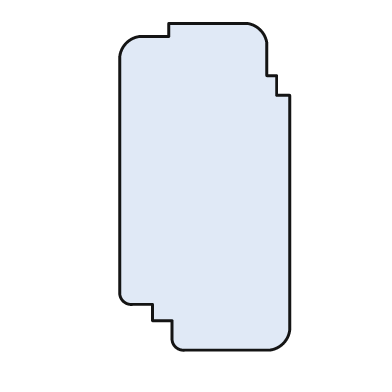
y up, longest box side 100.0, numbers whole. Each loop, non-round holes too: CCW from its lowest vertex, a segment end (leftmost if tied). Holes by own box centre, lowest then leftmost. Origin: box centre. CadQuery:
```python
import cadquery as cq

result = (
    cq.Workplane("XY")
    .moveTo(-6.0, -50.0)
    .lineTo(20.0, -50.0)
    .threePointArc((24.0, -48.0), (26.0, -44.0))
    .lineTo(26.0, 28.0)
    .lineTo(22.0, 28.0)
    .lineTo(22.0, 34.0)
    .lineTo(19.0, 34.0)
    .lineTo(19.0, 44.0)
    .threePointArc((17.0, 48.0), (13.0, 50.0))
    .lineTo(-11.0, 50.0)
    .lineTo(-11.0, 46.0)
    .lineTo(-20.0, 46.0)
    .threePointArc((-24.0, 44.0), (-26.0, 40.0))
    .lineTo(-26.0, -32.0)
    .threePointArc((-25.0, -35.0), (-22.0, -36.0))
    .lineTo(-16.0, -36.0)
    .lineTo(-16.0, -41.0)
    .lineTo(-10.0, -41.0)
    .lineTo(-10.0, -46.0)
    .threePointArc((-9.0, -49.0), (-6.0, -50.0))
    .close()
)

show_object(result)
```